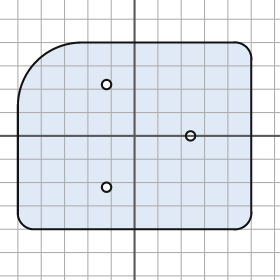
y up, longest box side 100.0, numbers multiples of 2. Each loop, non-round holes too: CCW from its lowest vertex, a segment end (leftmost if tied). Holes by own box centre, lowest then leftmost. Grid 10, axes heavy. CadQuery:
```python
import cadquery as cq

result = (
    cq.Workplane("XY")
    .moveTo(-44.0, -40.0)
    .lineTo(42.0, -40.0)
    .threePointArc((48.0, -38.0), (50.0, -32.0))
    .lineTo(50.0, 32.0)
    .threePointArc((48.0, 38.0), (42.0, 40.0))
    .lineTo(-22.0, 40.0)
    .threePointArc((-42.0, 32.0), (-50.0, 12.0))
    .lineTo(-50.0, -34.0)
    .threePointArc((-48.0, -38.0), (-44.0, -40.0))
    .close()
    .moveTo(-12.0, -22.0)
    .circle(2.0)
    .moveTo(24.0, 0.0)
    .circle(2.0)
    .moveTo(-12.0, 22.0)
    .circle(2.0)
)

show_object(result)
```